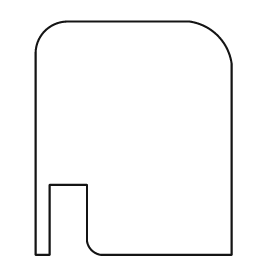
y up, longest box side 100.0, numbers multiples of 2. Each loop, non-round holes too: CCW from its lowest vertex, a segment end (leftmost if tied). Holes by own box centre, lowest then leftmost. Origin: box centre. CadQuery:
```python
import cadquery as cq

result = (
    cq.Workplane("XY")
    .moveTo(-42.0, -50.0)
    .lineTo(-36.0, -50.0)
    .lineTo(-36.0, -20.0)
    .lineTo(-20.0, -20.0)
    .lineTo(-20.0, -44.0)
    .threePointArc((-18.0, -48.0), (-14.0, -50.0))
    .lineTo(42.0, -50.0)
    .lineTo(42.0, 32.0)
    .threePointArc((36.0, 44.0), (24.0, 50.0))
    .lineTo(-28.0, 50.0)
    .threePointArc((-38.0, 46.0), (-42.0, 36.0))
    .close()
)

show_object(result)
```